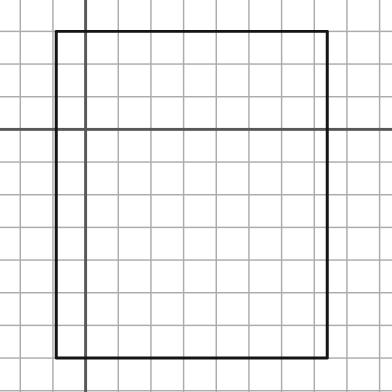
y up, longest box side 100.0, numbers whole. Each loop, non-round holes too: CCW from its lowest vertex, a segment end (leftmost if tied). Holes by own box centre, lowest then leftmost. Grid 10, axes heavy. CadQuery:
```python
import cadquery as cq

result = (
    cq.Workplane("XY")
    .moveTo(-9.0, -70.0)
    .lineTo(74.0, -70.0)
    .lineTo(74.0, 30.0)
    .lineTo(-9.0, 30.0)
    .close()
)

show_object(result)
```